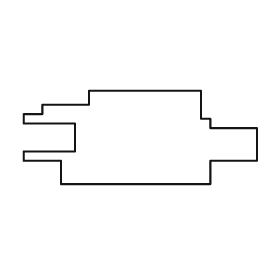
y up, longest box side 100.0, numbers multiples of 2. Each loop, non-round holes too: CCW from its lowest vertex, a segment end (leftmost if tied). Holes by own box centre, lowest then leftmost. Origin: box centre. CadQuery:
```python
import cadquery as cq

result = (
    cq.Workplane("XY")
    .moveTo(-34.0, -20.0)
    .lineTo(30.0, -20.0)
    .lineTo(30.0, -10.0)
    .lineTo(50.0, -10.0)
    .lineTo(50.0, 4.0)
    .lineTo(30.0, 4.0)
    .lineTo(30.0, 8.0)
    .lineTo(26.0, 8.0)
    .lineTo(26.0, 20.0)
    .lineTo(-22.0, 20.0)
    .lineTo(-22.0, 14.0)
    .lineTo(-42.0, 14.0)
    .lineTo(-42.0, 10.0)
    .lineTo(-50.0, 10.0)
    .lineTo(-50.0, 6.0)
    .lineTo(-28.0, 6.0)
    .lineTo(-28.0, -6.0)
    .lineTo(-50.0, -6.0)
    .lineTo(-50.0, -10.0)
    .lineTo(-34.0, -10.0)
    .close()
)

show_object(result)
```